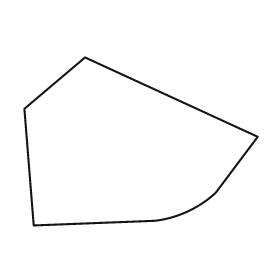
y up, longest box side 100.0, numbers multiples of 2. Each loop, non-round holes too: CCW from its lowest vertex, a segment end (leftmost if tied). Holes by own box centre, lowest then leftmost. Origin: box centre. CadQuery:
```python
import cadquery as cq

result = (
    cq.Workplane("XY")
    .moveTo(-46.0, -36.0)
    .lineTo(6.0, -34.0)
    .threePointArc((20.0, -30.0), (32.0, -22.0))
    .lineTo(50.0, 2.0)
    .lineTo(-24.0, 36.0)
    .lineTo(-50.0, 14.0)
    .close()
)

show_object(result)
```